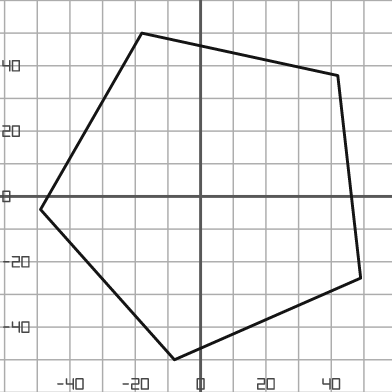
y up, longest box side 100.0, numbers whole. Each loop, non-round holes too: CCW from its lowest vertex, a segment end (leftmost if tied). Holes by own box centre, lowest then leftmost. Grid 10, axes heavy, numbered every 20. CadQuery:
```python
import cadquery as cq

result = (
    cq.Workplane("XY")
    .moveTo(-8.0, -50.0)
    .lineTo(49.0, -25.0)
    .lineTo(42.0, 37.0)
    .lineTo(-18.0, 50.0)
    .lineTo(-49.0, -4.0)
    .close()
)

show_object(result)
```